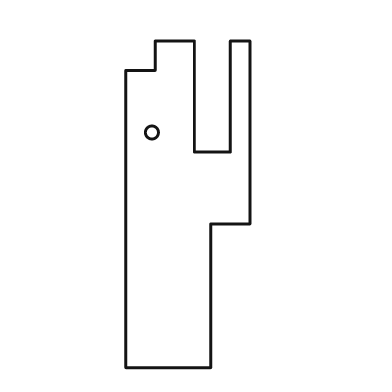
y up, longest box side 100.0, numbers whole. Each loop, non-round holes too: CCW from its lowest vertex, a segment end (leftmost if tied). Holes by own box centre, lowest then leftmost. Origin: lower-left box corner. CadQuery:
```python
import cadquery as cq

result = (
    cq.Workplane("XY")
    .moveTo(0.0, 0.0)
    .lineTo(26.0, 0.0)
    .lineTo(26.0, 44.0)
    .lineTo(38.0, 44.0)
    .lineTo(38.0, 100.0)
    .lineTo(32.0, 100.0)
    .lineTo(32.0, 66.0)
    .lineTo(21.0, 66.0)
    .lineTo(21.0, 100.0)
    .lineTo(9.0, 100.0)
    .lineTo(9.0, 91.0)
    .lineTo(0.0, 91.0)
    .close()
    .moveTo(8.0, 72.0)
    .circle(2.0)
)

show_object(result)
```